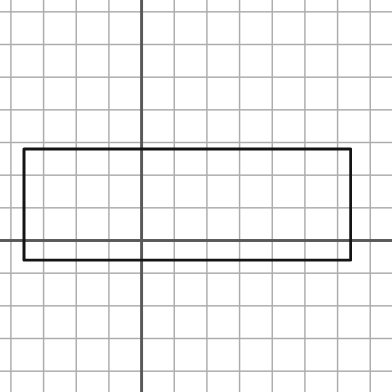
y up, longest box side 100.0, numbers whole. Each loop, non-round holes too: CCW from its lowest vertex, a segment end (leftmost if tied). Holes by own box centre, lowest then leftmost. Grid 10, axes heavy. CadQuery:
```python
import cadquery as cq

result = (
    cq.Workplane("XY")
    .moveTo(-36.0, -6.0)
    .lineTo(64.0, -6.0)
    .lineTo(64.0, 28.0)
    .lineTo(-36.0, 28.0)
    .close()
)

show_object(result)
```